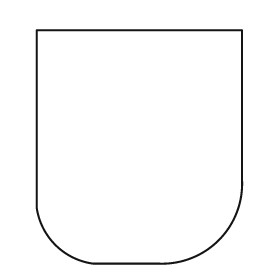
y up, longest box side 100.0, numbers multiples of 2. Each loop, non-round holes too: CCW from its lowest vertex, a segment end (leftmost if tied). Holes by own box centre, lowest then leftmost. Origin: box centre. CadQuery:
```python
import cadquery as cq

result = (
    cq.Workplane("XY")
    .moveTo(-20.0, -50.0)
    .lineTo(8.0, -50.0)
    .threePointArc((34.0, -40.0), (44.0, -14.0))
    .lineTo(44.0, 50.0)
    .lineTo(-44.0, 50.0)
    .lineTo(-44.0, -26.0)
    .threePointArc((-36.0, -42.0), (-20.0, -50.0))
    .close()
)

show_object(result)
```